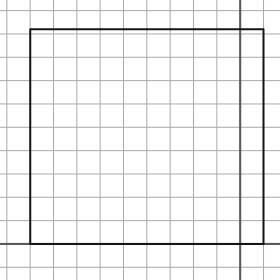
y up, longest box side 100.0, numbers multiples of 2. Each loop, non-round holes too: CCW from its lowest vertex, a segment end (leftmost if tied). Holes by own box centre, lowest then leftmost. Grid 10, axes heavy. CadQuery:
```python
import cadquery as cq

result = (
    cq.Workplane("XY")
    .moveTo(-90.0, 0.0)
    .lineTo(10.0, 0.0)
    .lineTo(10.0, 92.0)
    .lineTo(-90.0, 92.0)
    .close()
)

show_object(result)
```